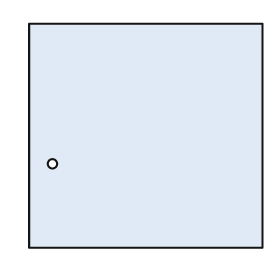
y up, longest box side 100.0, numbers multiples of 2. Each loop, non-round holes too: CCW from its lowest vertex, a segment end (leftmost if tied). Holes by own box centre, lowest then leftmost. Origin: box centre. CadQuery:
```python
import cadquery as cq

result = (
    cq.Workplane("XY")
    .moveTo(-50.0, -48.0)
    .lineTo(50.0, -48.0)
    .lineTo(50.0, 48.0)
    .lineTo(-50.0, 48.0)
    .close()
    .moveTo(-40.0, -12.0)
    .circle(2.0)
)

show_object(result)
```